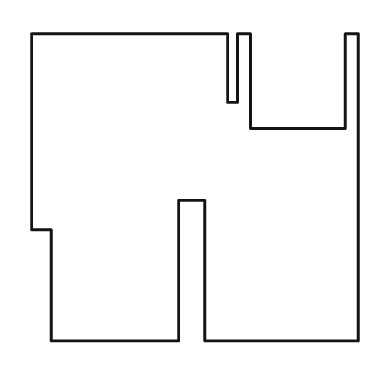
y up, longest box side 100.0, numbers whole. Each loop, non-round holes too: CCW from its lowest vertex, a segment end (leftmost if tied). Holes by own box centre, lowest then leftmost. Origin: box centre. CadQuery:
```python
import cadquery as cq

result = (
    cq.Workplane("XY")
    .moveTo(-44.0, -47.0)
    .lineTo(-5.0, -47.0)
    .lineTo(-5.0, -4.0)
    .lineTo(3.0, -4.0)
    .lineTo(3.0, -47.0)
    .lineTo(50.0, -47.0)
    .lineTo(50.0, 47.0)
    .lineTo(46.0, 47.0)
    .lineTo(46.0, 18.0)
    .lineTo(17.0, 18.0)
    .lineTo(17.0, 47.0)
    .lineTo(13.0, 47.0)
    .lineTo(13.0, 26.0)
    .lineTo(10.0, 26.0)
    .lineTo(10.0, 47.0)
    .lineTo(-50.0, 47.0)
    .lineTo(-50.0, -13.0)
    .lineTo(-44.0, -13.0)
    .close()
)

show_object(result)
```